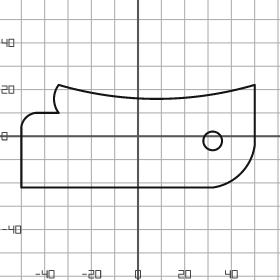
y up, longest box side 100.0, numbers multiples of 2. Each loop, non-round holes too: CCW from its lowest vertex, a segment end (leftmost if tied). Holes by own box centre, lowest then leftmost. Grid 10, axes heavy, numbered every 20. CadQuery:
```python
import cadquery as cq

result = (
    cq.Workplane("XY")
    .moveTo(-50.0, -22.0)
    .lineTo(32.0, -22.0)
    .threePointArc((44.0, -16.0), (50.0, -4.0))
    .lineTo(50.0, 22.0)
    .threePointArc((8.0, 16.0), (-34.0, 22.0))
    .threePointArc((-36.0, 16.0), (-34.0, 10.0))
    .lineTo(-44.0, 10.0)
    .threePointArc((-48.0, 8.0), (-50.0, 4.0))
    .close()
    .moveTo(32.0, -2.0)
    .circle(4.0)
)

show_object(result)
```